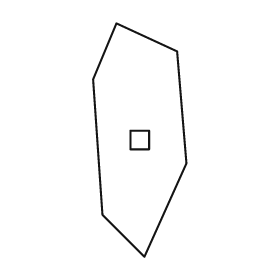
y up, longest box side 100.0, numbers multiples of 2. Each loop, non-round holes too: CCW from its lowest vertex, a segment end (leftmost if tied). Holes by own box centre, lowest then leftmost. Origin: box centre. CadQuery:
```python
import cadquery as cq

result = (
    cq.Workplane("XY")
    .moveTo(2.0, -50.0)
    .lineTo(20.0, -10.0)
    .lineTo(16.0, 38.0)
    .lineTo(-10.0, 50.0)
    .lineTo(-20.0, 26.0)
    .lineTo(-16.0, -32.0)
    .close()
    .moveTo(-4.0, -4.0)
    .lineTo(4.0, -4.0)
    .lineTo(4.0, 4.0)
    .lineTo(-4.0, 4.0)
    .close()
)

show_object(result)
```